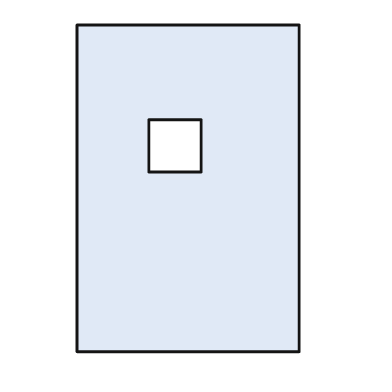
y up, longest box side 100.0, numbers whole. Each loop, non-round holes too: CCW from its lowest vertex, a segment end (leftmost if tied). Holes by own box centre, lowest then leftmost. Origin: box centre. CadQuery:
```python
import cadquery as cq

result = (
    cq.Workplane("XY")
    .moveTo(-34.0, -50.0)
    .lineTo(34.0, -50.0)
    .lineTo(34.0, 50.0)
    .lineTo(-34.0, 50.0)
    .close()
    .moveTo(-12.0, 5.0)
    .lineTo(4.0, 5.0)
    .lineTo(4.0, 21.0)
    .lineTo(-12.0, 21.0)
    .close()
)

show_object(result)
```